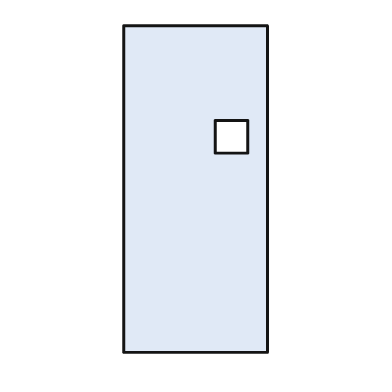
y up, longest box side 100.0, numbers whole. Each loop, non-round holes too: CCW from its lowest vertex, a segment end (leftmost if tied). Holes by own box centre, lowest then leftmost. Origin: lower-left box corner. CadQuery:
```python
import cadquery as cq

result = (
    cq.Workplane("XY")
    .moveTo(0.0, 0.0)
    .lineTo(44.0, 0.0)
    .lineTo(44.0, 100.0)
    .lineTo(0.0, 100.0)
    .close()
    .moveTo(28.0, 61.0)
    .lineTo(38.0, 61.0)
    .lineTo(38.0, 71.0)
    .lineTo(28.0, 71.0)
    .close()
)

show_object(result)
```